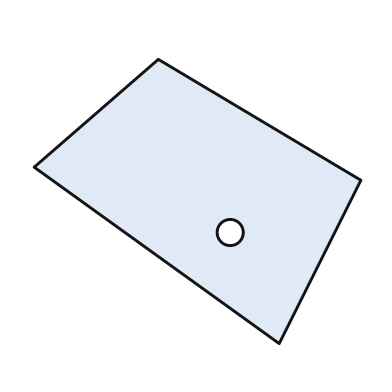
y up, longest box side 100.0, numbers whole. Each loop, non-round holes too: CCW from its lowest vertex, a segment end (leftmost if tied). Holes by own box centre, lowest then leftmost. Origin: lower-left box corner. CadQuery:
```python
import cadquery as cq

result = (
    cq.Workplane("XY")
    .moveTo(75.0, 0.0)
    .lineTo(100.0, 50.0)
    .lineTo(38.0, 87.0)
    .lineTo(0.0, 54.0)
    .close()
    .moveTo(60.0, 34.0)
    .circle(4.0)
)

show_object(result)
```